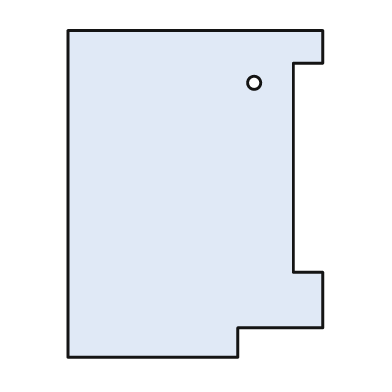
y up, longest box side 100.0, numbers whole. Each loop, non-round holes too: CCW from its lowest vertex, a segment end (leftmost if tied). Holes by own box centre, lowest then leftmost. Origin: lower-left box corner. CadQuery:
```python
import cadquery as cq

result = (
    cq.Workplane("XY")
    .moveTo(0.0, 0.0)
    .lineTo(52.0, 0.0)
    .lineTo(52.0, 9.0)
    .lineTo(78.0, 9.0)
    .lineTo(78.0, 26.0)
    .lineTo(69.0, 26.0)
    .lineTo(69.0, 90.0)
    .lineTo(78.0, 90.0)
    .lineTo(78.0, 100.0)
    .lineTo(0.0, 100.0)
    .close()
    .moveTo(57.0, 84.0)
    .circle(2.0)
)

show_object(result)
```